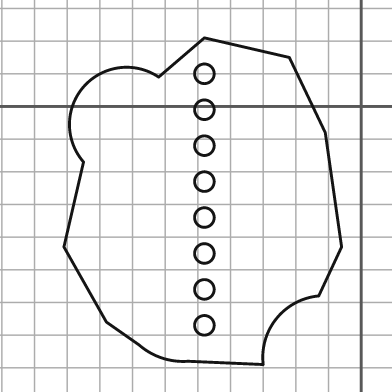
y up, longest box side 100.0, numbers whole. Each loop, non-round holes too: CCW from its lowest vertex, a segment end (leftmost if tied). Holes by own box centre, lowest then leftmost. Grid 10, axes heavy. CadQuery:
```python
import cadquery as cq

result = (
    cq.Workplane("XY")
    .moveTo(-30.0, -79.0)
    .threePointArc((-26.0, -65.0), (-13.0, -58.0))
    .lineTo(-6.0, -43.0)
    .lineTo(-11.0, -8.0)
    .lineTo(-22.0, 15.0)
    .lineTo(-48.0, 21.0)
    .lineTo(-62.0, 9.0)
    .threePointArc((-85.0, 6.0), (-85.0, -17.0))
    .lineTo(-91.0, -43.0)
    .lineTo(-78.0, -66.0)
    .lineTo(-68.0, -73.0)
    .threePointArc((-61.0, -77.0), (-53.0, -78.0))
    .close()
    .moveTo(-48.0, -67.0)
    .circle(3.0)
    .moveTo(-48.0, -56.0)
    .circle(3.0)
    .moveTo(-48.0, -45.0)
    .circle(3.0)
    .moveTo(-48.0, -34.0)
    .circle(3.0)
    .moveTo(-48.0, -23.0)
    .circle(3.0)
    .moveTo(-48.0, -12.0)
    .circle(3.0)
    .moveTo(-48.0, -1.0)
    .circle(3.0)
    .moveTo(-48.0, 10.0)
    .circle(3.0)
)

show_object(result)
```